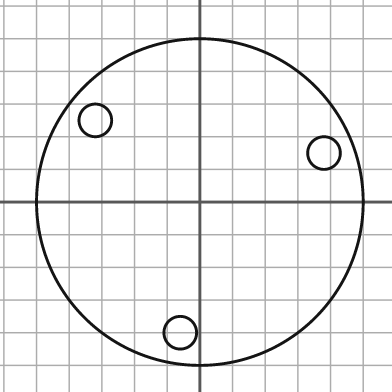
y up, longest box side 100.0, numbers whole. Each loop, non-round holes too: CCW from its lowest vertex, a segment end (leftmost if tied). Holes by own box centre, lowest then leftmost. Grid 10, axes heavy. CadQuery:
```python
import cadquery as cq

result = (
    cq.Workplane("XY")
    .moveTo(0.0, 0.0)
    .circle(50.0)
    .moveTo(-6.0, -40.0)
    .circle(5.0)
    .moveTo(38.0, 15.0)
    .circle(5.0)
    .moveTo(-32.0, 25.0)
    .circle(5.0)
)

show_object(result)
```